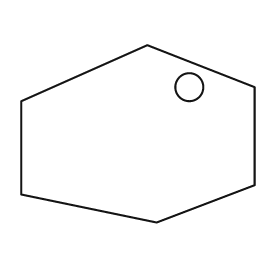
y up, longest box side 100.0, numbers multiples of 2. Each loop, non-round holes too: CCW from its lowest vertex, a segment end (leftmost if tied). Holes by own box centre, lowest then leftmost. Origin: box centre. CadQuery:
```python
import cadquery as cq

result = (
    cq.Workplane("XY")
    .moveTo(8.0, -38.0)
    .lineTo(50.0, -22.0)
    .lineTo(50.0, 20.0)
    .lineTo(4.0, 38.0)
    .lineTo(-50.0, 14.0)
    .lineTo(-50.0, -26.0)
    .close()
    .moveTo(22.0, 20.0)
    .circle(6.0)
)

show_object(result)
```